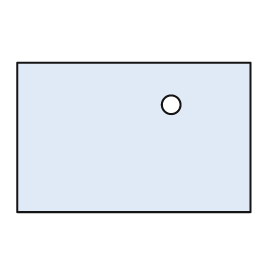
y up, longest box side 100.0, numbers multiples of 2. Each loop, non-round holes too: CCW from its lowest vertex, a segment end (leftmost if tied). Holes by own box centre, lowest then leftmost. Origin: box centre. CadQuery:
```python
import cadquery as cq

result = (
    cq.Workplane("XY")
    .moveTo(-50.0, -32.0)
    .lineTo(50.0, -32.0)
    .lineTo(50.0, 32.0)
    .lineTo(-50.0, 32.0)
    .close()
    .moveTo(16.0, 14.0)
    .circle(4.0)
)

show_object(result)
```